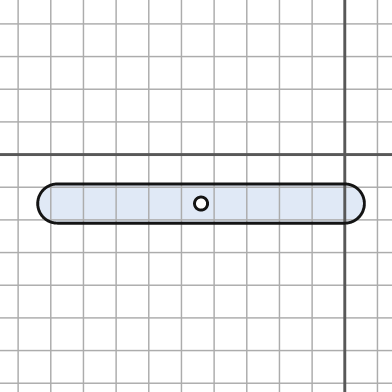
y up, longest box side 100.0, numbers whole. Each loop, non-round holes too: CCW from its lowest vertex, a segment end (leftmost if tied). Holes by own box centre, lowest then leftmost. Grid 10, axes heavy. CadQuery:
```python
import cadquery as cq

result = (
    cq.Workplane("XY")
    .moveTo(-88.0, -21.0)
    .lineTo(0.0, -21.0)
    .threePointArc((6.0, -15.0), (0.0, -9.0))
    .lineTo(-88.0, -9.0)
    .threePointArc((-94.0, -15.0), (-88.0, -21.0))
    .close()
    .moveTo(-44.0, -15.0)
    .circle(2.0)
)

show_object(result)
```